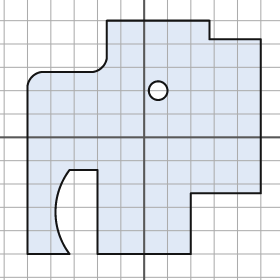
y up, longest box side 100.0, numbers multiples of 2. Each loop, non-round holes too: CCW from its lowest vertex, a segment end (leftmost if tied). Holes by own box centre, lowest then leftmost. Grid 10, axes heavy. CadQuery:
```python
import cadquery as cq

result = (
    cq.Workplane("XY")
    .moveTo(-50.0, -50.0)
    .lineTo(-32.0, -50.0)
    .threePointArc((-38.0, -32.0), (-32.0, -14.0))
    .lineTo(-20.0, -14.0)
    .lineTo(-20.0, -50.0)
    .lineTo(20.0, -50.0)
    .lineTo(20.0, -24.0)
    .lineTo(50.0, -24.0)
    .lineTo(50.0, 42.0)
    .lineTo(28.0, 42.0)
    .lineTo(28.0, 50.0)
    .lineTo(-16.0, 50.0)
    .lineTo(-16.0, 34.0)
    .threePointArc((-18.0, 30.0), (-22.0, 28.0))
    .lineTo(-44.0, 28.0)
    .threePointArc((-48.0, 26.0), (-50.0, 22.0))
    .close()
    .moveTo(6.0, 20.0)
    .circle(4.0)
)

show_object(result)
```